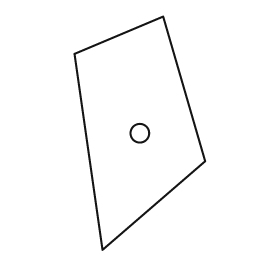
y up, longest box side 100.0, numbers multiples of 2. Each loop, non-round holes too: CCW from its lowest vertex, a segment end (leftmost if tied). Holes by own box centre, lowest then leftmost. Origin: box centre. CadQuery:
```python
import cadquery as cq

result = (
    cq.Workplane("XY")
    .moveTo(-16.0, -50.0)
    .lineTo(28.0, -12.0)
    .lineTo(10.0, 50.0)
    .lineTo(-28.0, 34.0)
    .close()
    .moveTo(0.0, 0.0)
    .circle(4.0)
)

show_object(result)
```